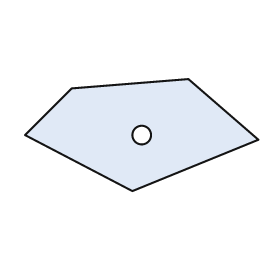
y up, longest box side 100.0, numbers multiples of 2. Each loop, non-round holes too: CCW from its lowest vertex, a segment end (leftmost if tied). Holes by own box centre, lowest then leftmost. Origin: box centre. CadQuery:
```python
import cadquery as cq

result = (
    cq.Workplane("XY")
    .moveTo(-4.0, -24.0)
    .lineTo(50.0, -2.0)
    .lineTo(20.0, 24.0)
    .lineTo(-30.0, 20.0)
    .lineTo(-50.0, 0.0)
    .close()
    .moveTo(0.0, 0.0)
    .circle(4.0)
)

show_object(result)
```